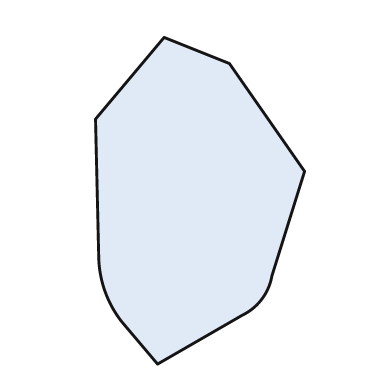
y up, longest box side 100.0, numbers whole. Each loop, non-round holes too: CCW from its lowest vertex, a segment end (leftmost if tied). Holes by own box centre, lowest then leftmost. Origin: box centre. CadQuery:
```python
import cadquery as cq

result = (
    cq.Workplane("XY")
    .moveTo(-13.0, -50.0)
    .lineTo(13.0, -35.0)
    .threePointArc((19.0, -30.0), (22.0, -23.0))
    .lineTo(32.0, 9.0)
    .lineTo(9.0, 42.0)
    .lineTo(-11.0, 50.0)
    .lineTo(-32.0, 25.0)
    .lineTo(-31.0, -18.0)
    .threePointArc((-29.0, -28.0), (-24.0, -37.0))
    .close()
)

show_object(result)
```